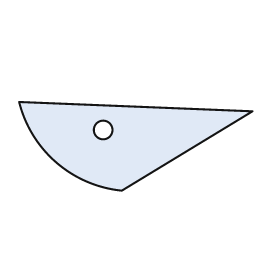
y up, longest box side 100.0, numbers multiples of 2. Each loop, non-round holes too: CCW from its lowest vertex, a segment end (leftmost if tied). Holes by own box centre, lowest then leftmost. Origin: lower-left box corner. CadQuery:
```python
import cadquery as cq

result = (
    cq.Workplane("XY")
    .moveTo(44.0, 0.0)
    .lineTo(100.0, 34.0)
    .lineTo(0.0, 38.0)
    .threePointArc((16.0, 12.0), (44.0, 0.0))
    .close()
    .moveTo(36.0, 26.0)
    .circle(4.0)
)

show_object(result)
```